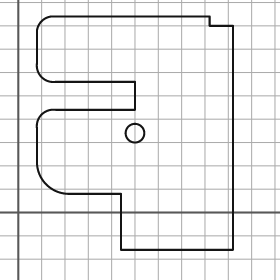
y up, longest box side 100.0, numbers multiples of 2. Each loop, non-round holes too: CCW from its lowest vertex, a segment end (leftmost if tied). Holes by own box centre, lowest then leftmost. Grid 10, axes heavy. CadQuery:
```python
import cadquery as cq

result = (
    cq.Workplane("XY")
    .moveTo(44.0, -16.0)
    .lineTo(92.0, -16.0)
    .lineTo(92.0, 80.0)
    .lineTo(82.0, 80.0)
    .lineTo(82.0, 84.0)
    .lineTo(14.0, 84.0)
    .threePointArc((10.0, 82.0), (8.0, 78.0))
    .lineTo(8.0, 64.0)
    .threePointArc((10.0, 58.0), (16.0, 56.0))
    .lineTo(50.0, 56.0)
    .lineTo(50.0, 44.0)
    .lineTo(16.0, 44.0)
    .threePointArc((10.0, 42.0), (8.0, 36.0))
    .lineTo(8.0, 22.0)
    .threePointArc((12.0, 12.0), (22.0, 8.0))
    .lineTo(44.0, 8.0)
    .close()
    .moveTo(50.0, 34.0)
    .circle(4.0)
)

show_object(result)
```